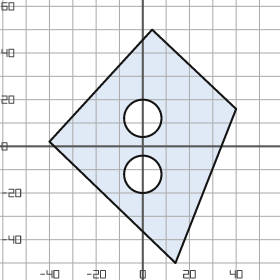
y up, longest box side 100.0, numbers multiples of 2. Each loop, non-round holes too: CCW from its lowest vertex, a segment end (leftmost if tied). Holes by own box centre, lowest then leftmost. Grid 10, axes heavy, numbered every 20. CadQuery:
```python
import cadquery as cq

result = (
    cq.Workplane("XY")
    .moveTo(14.0, -50.0)
    .lineTo(40.0, 16.0)
    .lineTo(4.0, 50.0)
    .lineTo(-40.0, 2.0)
    .close()
    .moveTo(0.0, -12.0)
    .circle(8.0)
    .moveTo(0.0, 12.0)
    .circle(8.0)
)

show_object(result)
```